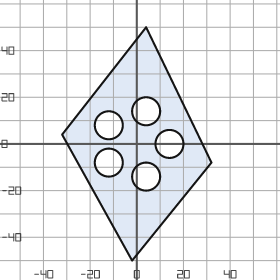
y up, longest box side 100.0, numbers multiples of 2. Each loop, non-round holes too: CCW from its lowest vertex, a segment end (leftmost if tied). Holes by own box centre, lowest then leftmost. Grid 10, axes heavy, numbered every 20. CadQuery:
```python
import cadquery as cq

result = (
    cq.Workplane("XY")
    .moveTo(-2.0, -50.0)
    .lineTo(32.0, -8.0)
    .lineTo(4.0, 50.0)
    .lineTo(-32.0, 4.0)
    .close()
    .moveTo(4.0, -14.0)
    .circle(6.0)
    .moveTo(-12.0, -8.0)
    .circle(6.0)
    .moveTo(14.0, 0.0)
    .circle(6.0)
    .moveTo(-12.0, 8.0)
    .circle(6.0)
    .moveTo(4.0, 14.0)
    .circle(6.0)
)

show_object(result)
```